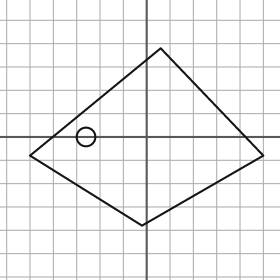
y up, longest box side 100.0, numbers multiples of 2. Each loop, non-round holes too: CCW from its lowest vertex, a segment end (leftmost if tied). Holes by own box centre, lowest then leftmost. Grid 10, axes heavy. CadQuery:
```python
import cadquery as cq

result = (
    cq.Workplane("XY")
    .moveTo(-2.0, -38.0)
    .lineTo(50.0, -8.0)
    .lineTo(6.0, 38.0)
    .lineTo(-50.0, -8.0)
    .close()
    .moveTo(-26.0, 0.0)
    .circle(4.0)
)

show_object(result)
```